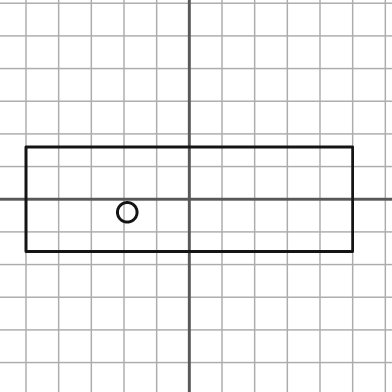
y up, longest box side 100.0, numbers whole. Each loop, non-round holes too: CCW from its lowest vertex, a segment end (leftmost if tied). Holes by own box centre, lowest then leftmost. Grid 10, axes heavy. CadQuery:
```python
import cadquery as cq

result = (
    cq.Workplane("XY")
    .moveTo(-50.0, -16.0)
    .lineTo(50.0, -16.0)
    .lineTo(50.0, 16.0)
    .lineTo(-50.0, 16.0)
    .close()
    .moveTo(-19.0, -4.0)
    .circle(3.0)
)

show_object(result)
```